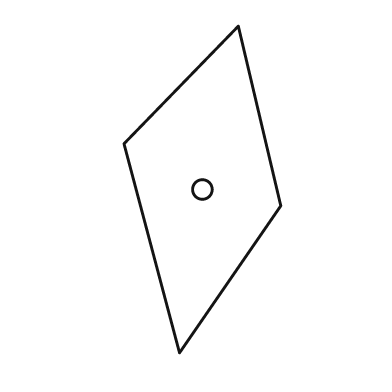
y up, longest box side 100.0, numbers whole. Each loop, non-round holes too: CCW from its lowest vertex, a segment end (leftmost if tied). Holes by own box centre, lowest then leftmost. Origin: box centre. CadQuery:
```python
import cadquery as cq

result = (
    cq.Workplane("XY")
    .moveTo(-7.0, -50.0)
    .lineTo(24.0, -5.0)
    .lineTo(11.0, 50.0)
    .lineTo(-24.0, 14.0)
    .close()
    .moveTo(0.0, 0.0)
    .circle(3.0)
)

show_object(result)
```